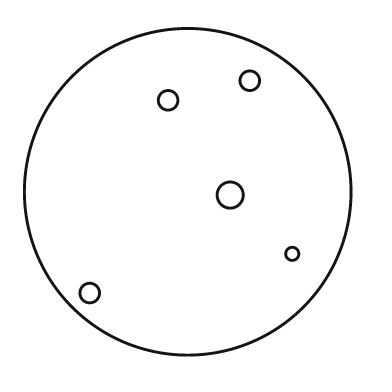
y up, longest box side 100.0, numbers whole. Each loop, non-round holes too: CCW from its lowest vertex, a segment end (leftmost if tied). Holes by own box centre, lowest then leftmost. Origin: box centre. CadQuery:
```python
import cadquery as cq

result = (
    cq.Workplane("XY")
    .moveTo(0.0, 0.0)
    .circle(50.0)
    .moveTo(-30.0, -31.0)
    .circle(3.0)
    .moveTo(32.0, -19.0)
    .circle(2.0)
    .moveTo(13.0, -1.0)
    .circle(4.0)
    .moveTo(-6.0, 28.0)
    .circle(3.0)
    .moveTo(19.0, 34.0)
    .circle(3.0)
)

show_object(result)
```